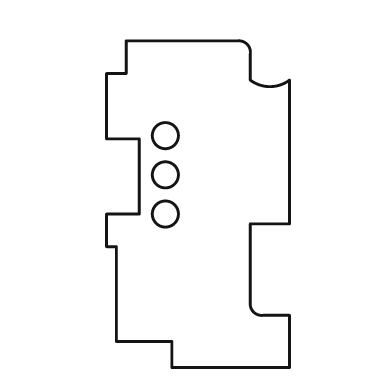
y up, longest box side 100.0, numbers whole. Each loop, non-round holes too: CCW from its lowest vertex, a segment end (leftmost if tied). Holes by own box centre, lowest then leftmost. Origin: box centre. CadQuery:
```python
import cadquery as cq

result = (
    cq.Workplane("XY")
    .moveTo(-8.0, -50.0)
    .lineTo(28.0, -50.0)
    .lineTo(28.0, -34.0)
    .lineTo(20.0, -34.0)
    .threePointArc((17.0, -33.0), (16.0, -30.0))
    .lineTo(16.0, -6.0)
    .lineTo(28.0, -6.0)
    .lineTo(28.0, 38.0)
    .threePointArc((22.0, 36.0), (16.0, 38.0))
    .lineTo(16.0, 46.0)
    .threePointArc((15.0, 49.0), (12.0, 50.0))
    .lineTo(-22.0, 50.0)
    .lineTo(-22.0, 40.0)
    .lineTo(-28.0, 40.0)
    .lineTo(-28.0, 20.0)
    .lineTo(-18.0, 20.0)
    .lineTo(-18.0, -3.0)
    .lineTo(-28.0, -3.0)
    .lineTo(-28.0, -13.0)
    .lineTo(-25.0, -13.0)
    .lineTo(-25.0, -42.0)
    .lineTo(-8.0, -42.0)
    .close()
    .moveTo(-10.0, -3.0)
    .circle(4.0)
    .moveTo(-10.0, 9.0)
    .circle(4.0)
    .moveTo(-10.0, 21.0)
    .circle(4.0)
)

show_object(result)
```